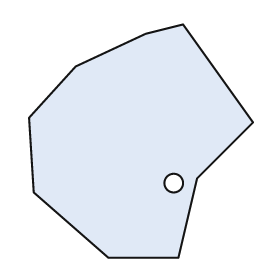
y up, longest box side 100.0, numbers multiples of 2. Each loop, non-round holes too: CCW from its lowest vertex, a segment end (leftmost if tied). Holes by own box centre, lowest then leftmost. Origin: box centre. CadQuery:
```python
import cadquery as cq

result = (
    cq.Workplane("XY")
    .moveTo(-14.0, -50.0)
    .lineTo(16.0, -50.0)
    .lineTo(24.0, -16.0)
    .lineTo(48.0, 8.0)
    .lineTo(18.0, 50.0)
    .lineTo(2.0, 46.0)
    .lineTo(-28.0, 32.0)
    .lineTo(-48.0, 10.0)
    .lineTo(-46.0, -22.0)
    .close()
    .moveTo(14.0, -18.0)
    .circle(4.0)
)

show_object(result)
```